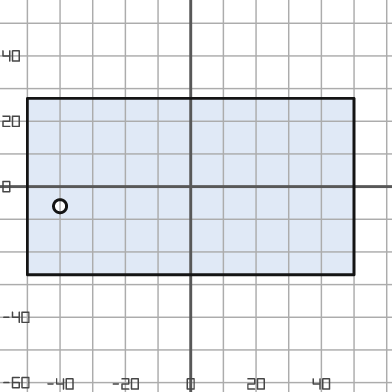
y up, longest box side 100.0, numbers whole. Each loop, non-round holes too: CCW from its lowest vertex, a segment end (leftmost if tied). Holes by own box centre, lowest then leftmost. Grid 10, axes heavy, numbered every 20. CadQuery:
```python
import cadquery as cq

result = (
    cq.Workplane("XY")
    .moveTo(-50.0, -27.0)
    .lineTo(50.0, -27.0)
    .lineTo(50.0, 27.0)
    .lineTo(-50.0, 27.0)
    .close()
    .moveTo(-40.0, -6.0)
    .circle(2.0)
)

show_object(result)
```